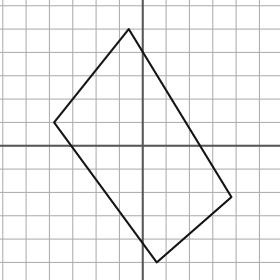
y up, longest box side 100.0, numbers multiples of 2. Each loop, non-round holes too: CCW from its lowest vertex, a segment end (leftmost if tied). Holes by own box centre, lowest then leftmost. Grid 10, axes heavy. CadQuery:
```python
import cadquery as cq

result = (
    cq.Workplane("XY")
    .moveTo(6.0, -50.0)
    .lineTo(38.0, -22.0)
    .lineTo(-6.0, 50.0)
    .lineTo(-38.0, 10.0)
    .close()
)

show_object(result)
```